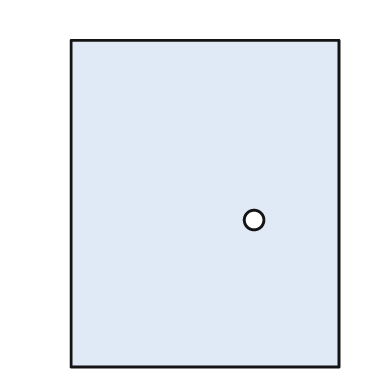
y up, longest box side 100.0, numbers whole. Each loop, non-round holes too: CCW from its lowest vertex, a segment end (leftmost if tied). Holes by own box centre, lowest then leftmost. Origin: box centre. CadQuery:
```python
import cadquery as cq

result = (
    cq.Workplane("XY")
    .moveTo(-41.0, -50.0)
    .lineTo(41.0, -50.0)
    .lineTo(41.0, 50.0)
    .lineTo(-41.0, 50.0)
    .close()
    .moveTo(15.0, -5.0)
    .circle(3.0)
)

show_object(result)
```